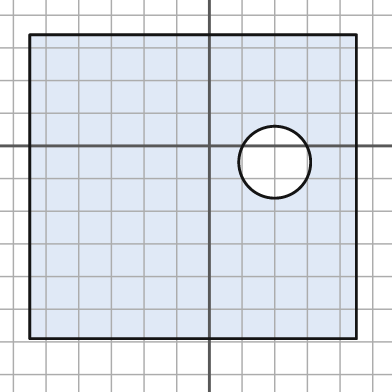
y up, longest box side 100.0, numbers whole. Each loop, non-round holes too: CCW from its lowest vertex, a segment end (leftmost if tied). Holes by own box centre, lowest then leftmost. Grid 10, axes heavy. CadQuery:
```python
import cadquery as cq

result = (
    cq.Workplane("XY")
    .moveTo(-55.0, -59.0)
    .lineTo(45.0, -59.0)
    .lineTo(45.0, 34.0)
    .lineTo(-55.0, 34.0)
    .close()
    .moveTo(20.0, -5.0)
    .circle(11.0)
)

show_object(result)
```